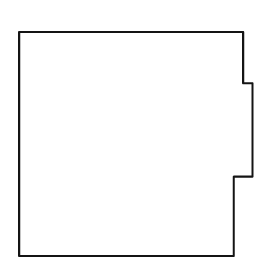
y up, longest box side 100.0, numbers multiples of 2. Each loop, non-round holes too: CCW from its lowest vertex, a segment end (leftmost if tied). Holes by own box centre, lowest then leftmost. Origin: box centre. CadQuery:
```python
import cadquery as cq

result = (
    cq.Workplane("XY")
    .moveTo(-50.0, -48.0)
    .lineTo(42.0, -48.0)
    .lineTo(42.0, -14.0)
    .lineTo(50.0, -14.0)
    .lineTo(50.0, 26.0)
    .lineTo(46.0, 26.0)
    .lineTo(46.0, 48.0)
    .lineTo(-50.0, 48.0)
    .close()
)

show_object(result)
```